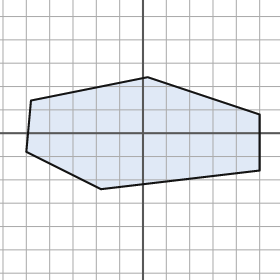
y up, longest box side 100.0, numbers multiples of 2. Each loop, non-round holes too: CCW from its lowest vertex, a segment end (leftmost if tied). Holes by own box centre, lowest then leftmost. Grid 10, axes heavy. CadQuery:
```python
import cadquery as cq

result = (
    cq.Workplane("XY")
    .moveTo(-18.0, -24.0)
    .lineTo(50.0, -16.0)
    .lineTo(50.0, 8.0)
    .lineTo(2.0, 24.0)
    .lineTo(-48.0, 14.0)
    .lineTo(-50.0, -8.0)
    .close()
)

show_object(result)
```